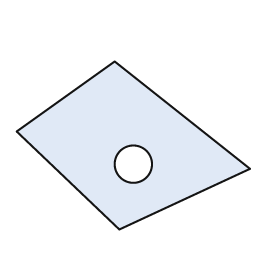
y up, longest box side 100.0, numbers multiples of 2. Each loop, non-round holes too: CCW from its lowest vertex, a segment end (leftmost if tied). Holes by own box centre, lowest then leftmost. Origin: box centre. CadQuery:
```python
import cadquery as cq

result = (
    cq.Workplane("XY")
    .moveTo(-6.0, -36.0)
    .lineTo(50.0, -10.0)
    .lineTo(-8.0, 36.0)
    .lineTo(-50.0, 6.0)
    .close()
    .moveTo(0.0, -8.0)
    .circle(8.0)
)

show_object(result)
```